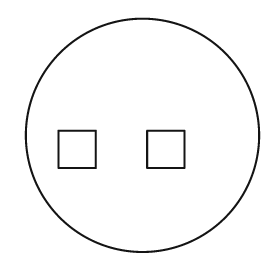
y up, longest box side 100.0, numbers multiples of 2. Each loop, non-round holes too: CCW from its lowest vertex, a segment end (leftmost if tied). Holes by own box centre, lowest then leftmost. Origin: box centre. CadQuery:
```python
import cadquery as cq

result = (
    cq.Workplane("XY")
    .moveTo(0.0, 0.0)
    .circle(50.0)
    .moveTo(-36.0, -14.0)
    .lineTo(-20.0, -14.0)
    .lineTo(-20.0, 2.0)
    .lineTo(-36.0, 2.0)
    .close()
    .moveTo(2.0, -14.0)
    .lineTo(18.0, -14.0)
    .lineTo(18.0, 2.0)
    .lineTo(2.0, 2.0)
    .close()
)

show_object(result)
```